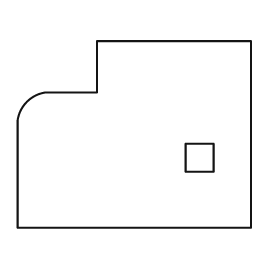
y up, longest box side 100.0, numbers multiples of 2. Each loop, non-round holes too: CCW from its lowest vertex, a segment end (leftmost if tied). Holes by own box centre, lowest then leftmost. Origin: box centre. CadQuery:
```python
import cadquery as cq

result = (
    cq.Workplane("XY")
    .moveTo(-50.0, -40.0)
    .lineTo(50.0, -40.0)
    .lineTo(50.0, 40.0)
    .lineTo(-16.0, 40.0)
    .lineTo(-16.0, 18.0)
    .lineTo(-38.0, 18.0)
    .threePointArc((-46.0, 14.0), (-50.0, 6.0))
    .close()
    .moveTo(22.0, -16.0)
    .lineTo(34.0, -16.0)
    .lineTo(34.0, -4.0)
    .lineTo(22.0, -4.0)
    .close()
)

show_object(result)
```